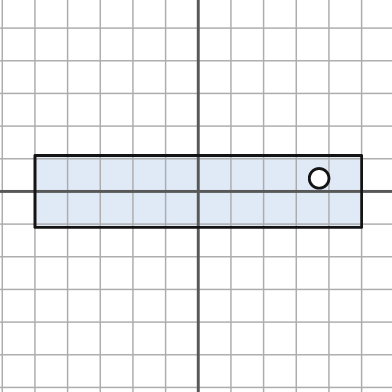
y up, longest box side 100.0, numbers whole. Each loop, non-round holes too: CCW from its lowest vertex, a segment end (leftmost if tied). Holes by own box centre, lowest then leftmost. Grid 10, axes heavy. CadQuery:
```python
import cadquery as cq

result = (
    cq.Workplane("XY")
    .moveTo(-50.0, -11.0)
    .lineTo(50.0, -11.0)
    .lineTo(50.0, 11.0)
    .lineTo(-50.0, 11.0)
    .close()
    .moveTo(37.0, 4.0)
    .circle(3.0)
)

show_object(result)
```